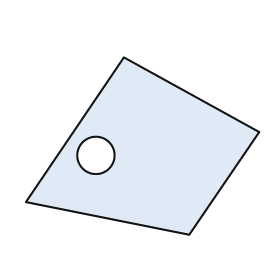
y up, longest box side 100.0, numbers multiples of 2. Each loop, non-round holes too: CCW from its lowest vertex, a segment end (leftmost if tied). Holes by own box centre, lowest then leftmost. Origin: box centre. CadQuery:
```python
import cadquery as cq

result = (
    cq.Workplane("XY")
    .moveTo(20.0, -38.0)
    .lineTo(50.0, 6.0)
    .lineTo(-8.0, 38.0)
    .lineTo(-50.0, -24.0)
    .close()
    .moveTo(-20.0, -4.0)
    .circle(8.0)
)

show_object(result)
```